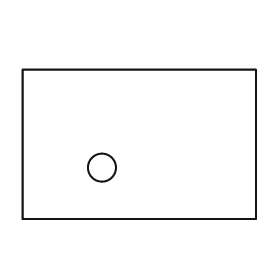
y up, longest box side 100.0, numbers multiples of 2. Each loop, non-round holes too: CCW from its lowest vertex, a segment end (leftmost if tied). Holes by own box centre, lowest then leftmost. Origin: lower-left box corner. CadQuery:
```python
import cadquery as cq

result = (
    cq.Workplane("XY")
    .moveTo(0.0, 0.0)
    .lineTo(100.0, 0.0)
    .lineTo(100.0, 64.0)
    .lineTo(0.0, 64.0)
    .close()
    .moveTo(34.0, 22.0)
    .circle(6.0)
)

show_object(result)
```